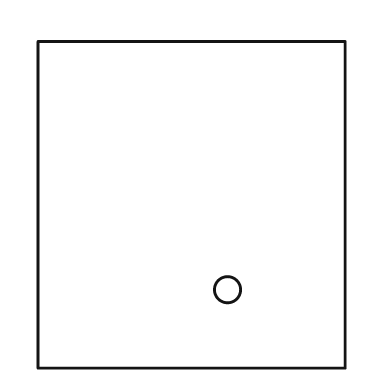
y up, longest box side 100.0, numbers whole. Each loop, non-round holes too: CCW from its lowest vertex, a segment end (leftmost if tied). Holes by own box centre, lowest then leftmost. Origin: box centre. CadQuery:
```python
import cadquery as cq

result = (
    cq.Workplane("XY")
    .moveTo(-47.0, -50.0)
    .lineTo(47.0, -50.0)
    .lineTo(47.0, 50.0)
    .lineTo(-47.0, 50.0)
    .close()
    .moveTo(11.0, -26.0)
    .circle(4.0)
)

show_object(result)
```